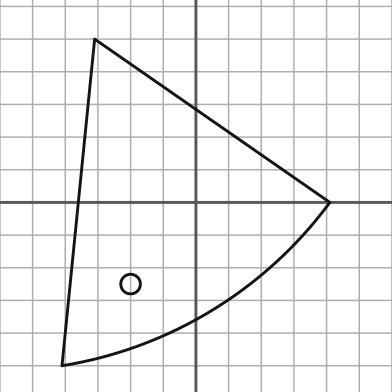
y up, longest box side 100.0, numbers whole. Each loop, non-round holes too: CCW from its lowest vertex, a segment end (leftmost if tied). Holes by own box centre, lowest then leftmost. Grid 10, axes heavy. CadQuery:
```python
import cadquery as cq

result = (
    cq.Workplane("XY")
    .moveTo(-41.0, -50.0)
    .threePointArc((5.0, -33.0), (41.0, 0.0))
    .lineTo(-31.0, 50.0)
    .close()
    .moveTo(-20.0, -25.0)
    .circle(3.0)
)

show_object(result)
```